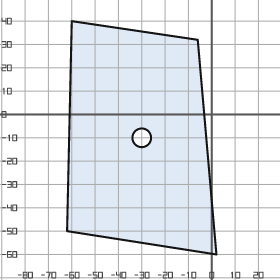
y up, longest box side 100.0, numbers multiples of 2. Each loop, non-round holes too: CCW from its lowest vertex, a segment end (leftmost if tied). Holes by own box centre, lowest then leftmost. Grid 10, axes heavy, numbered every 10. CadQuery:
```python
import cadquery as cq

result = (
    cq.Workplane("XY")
    .moveTo(2.0, -60.0)
    .lineTo(-6.0, 32.0)
    .lineTo(-60.0, 40.0)
    .lineTo(-62.0, -50.0)
    .close()
    .moveTo(-30.0, -10.0)
    .circle(4.0)
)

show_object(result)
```